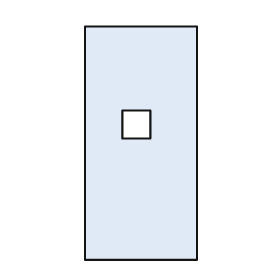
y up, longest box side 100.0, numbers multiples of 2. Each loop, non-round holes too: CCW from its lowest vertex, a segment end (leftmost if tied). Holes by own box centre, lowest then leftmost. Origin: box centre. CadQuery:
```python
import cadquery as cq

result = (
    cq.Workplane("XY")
    .moveTo(-24.0, -50.0)
    .lineTo(24.0, -50.0)
    .lineTo(24.0, 50.0)
    .lineTo(-24.0, 50.0)
    .close()
    .moveTo(-8.0, 2.0)
    .lineTo(4.0, 2.0)
    .lineTo(4.0, 14.0)
    .lineTo(-8.0, 14.0)
    .close()
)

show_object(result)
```